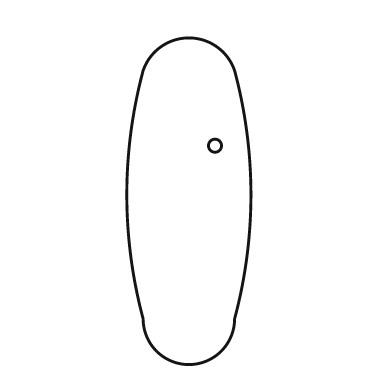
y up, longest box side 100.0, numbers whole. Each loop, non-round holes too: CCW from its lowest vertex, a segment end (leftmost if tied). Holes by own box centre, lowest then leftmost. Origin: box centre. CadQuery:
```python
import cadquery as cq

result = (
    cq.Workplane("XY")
    .moveTo(-14.0, -36.0)
    .threePointArc((0.0, -50.0), (14.0, -36.0))
    .threePointArc((19.0, 2.0), (14.0, 40.0))
    .threePointArc((0.0, 50.0), (-14.0, 40.0))
    .threePointArc((-19.0, 2.0), (-14.0, -36.0))
    .close()
    .moveTo(8.0, 17.0)
    .circle(2.0)
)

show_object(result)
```